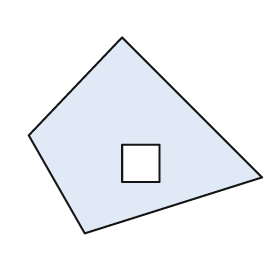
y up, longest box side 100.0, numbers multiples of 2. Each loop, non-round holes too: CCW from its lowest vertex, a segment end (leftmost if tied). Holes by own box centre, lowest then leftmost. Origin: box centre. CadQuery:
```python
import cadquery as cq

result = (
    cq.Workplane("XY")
    .moveTo(-26.0, -42.0)
    .lineTo(50.0, -18.0)
    .lineTo(-10.0, 42.0)
    .lineTo(-50.0, 0.0)
    .close()
    .moveTo(-10.0, -20.0)
    .lineTo(6.0, -20.0)
    .lineTo(6.0, -4.0)
    .lineTo(-10.0, -4.0)
    .close()
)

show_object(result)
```